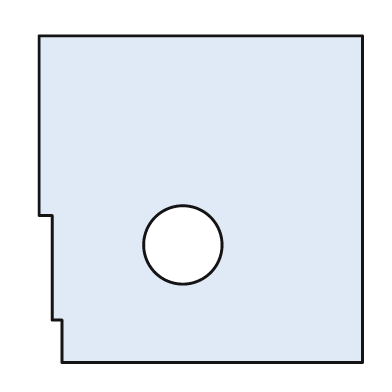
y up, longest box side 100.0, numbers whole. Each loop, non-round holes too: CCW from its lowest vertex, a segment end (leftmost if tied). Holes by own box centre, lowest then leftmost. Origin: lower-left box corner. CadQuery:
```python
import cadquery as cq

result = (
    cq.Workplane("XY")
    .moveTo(7.0, 0.0)
    .lineTo(99.0, 0.0)
    .lineTo(99.0, 100.0)
    .lineTo(0.0, 100.0)
    .lineTo(0.0, 45.0)
    .lineTo(4.0, 45.0)
    .lineTo(4.0, 13.0)
    .lineTo(7.0, 13.0)
    .close()
    .moveTo(44.0, 36.0)
    .circle(12.0)
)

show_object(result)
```